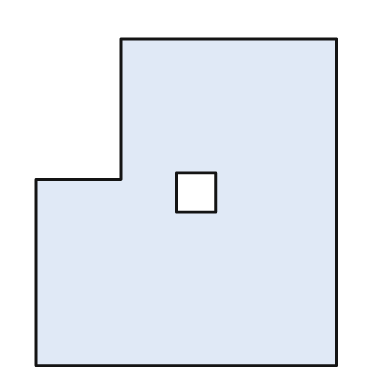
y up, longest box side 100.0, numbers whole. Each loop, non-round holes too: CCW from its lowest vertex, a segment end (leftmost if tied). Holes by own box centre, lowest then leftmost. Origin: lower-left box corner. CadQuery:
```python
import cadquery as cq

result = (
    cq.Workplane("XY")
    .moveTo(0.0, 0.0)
    .lineTo(92.0, 0.0)
    .lineTo(92.0, 100.0)
    .lineTo(26.0, 100.0)
    .lineTo(26.0, 57.0)
    .lineTo(0.0, 57.0)
    .close()
    .moveTo(43.0, 47.0)
    .lineTo(55.0, 47.0)
    .lineTo(55.0, 59.0)
    .lineTo(43.0, 59.0)
    .close()
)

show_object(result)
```